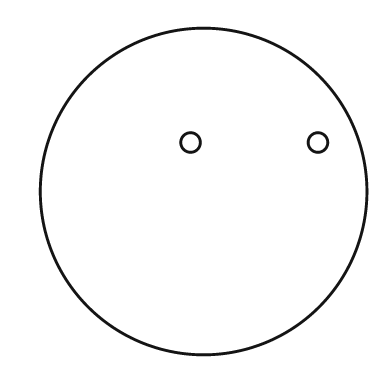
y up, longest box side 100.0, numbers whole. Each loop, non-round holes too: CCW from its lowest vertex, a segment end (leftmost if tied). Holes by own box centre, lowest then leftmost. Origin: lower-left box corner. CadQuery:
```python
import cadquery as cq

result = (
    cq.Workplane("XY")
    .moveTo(50.0, 50.0)
    .circle(50.0)
    .moveTo(46.0, 65.0)
    .circle(3.0)
    .moveTo(85.0, 65.0)
    .circle(3.0)
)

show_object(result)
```